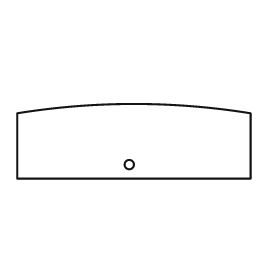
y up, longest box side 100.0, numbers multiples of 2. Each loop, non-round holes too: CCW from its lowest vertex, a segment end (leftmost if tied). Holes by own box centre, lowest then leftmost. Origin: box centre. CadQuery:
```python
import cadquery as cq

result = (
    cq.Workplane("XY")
    .moveTo(-50.0, -16.0)
    .lineTo(50.0, -16.0)
    .lineTo(50.0, 12.0)
    .threePointArc((0.0, 16.0), (-50.0, 12.0))
    .close()
    .moveTo(-2.0, -10.0)
    .circle(2.0)
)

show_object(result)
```